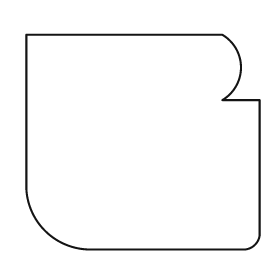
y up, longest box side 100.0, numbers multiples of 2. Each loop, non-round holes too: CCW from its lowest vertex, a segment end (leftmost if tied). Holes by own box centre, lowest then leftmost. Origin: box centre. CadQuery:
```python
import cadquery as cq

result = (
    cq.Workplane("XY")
    .moveTo(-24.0, -46.0)
    .lineTo(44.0, -46.0)
    .threePointArc((48.0, -44.0), (50.0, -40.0))
    .lineTo(50.0, 18.0)
    .lineTo(34.0, 18.0)
    .threePointArc((42.0, 32.0), (34.0, 46.0))
    .lineTo(-50.0, 46.0)
    .lineTo(-50.0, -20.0)
    .threePointArc((-42.0, -38.0), (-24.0, -46.0))
    .close()
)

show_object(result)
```